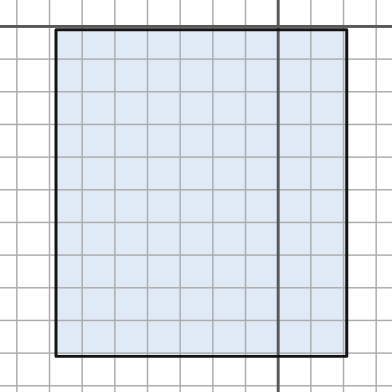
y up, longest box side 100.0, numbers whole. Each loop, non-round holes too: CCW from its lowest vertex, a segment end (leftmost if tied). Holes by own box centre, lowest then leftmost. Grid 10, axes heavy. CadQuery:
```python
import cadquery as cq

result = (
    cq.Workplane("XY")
    .moveTo(-68.0, -101.0)
    .lineTo(21.0, -101.0)
    .lineTo(21.0, -1.0)
    .lineTo(-68.0, -1.0)
    .close()
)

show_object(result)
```